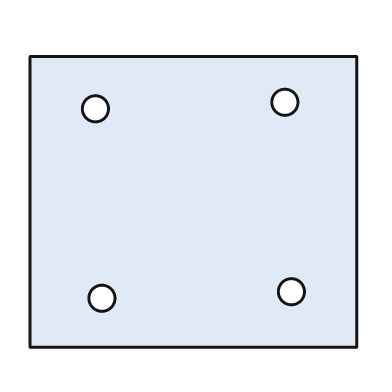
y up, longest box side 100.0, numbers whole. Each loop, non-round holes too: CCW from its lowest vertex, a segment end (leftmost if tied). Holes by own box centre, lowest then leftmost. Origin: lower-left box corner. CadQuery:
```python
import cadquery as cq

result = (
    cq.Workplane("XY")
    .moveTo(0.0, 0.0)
    .lineTo(100.0, 0.0)
    .lineTo(100.0, 89.0)
    .lineTo(0.0, 89.0)
    .close()
    .moveTo(22.0, 15.0)
    .circle(4.0)
    .moveTo(80.0, 17.0)
    .circle(4.0)
    .moveTo(20.0, 73.0)
    .circle(4.0)
    .moveTo(78.0, 75.0)
    .circle(4.0)
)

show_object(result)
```